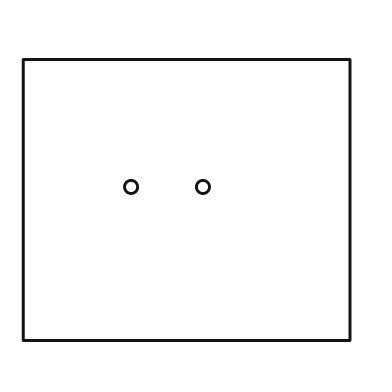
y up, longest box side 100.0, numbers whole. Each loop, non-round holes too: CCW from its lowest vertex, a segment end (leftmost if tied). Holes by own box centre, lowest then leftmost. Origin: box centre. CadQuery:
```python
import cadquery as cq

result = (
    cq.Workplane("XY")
    .moveTo(-50.0, -43.0)
    .lineTo(50.0, -43.0)
    .lineTo(50.0, 43.0)
    .lineTo(-50.0, 43.0)
    .close()
    .moveTo(-17.0, 4.0)
    .circle(2.0)
    .moveTo(5.0, 4.0)
    .circle(2.0)
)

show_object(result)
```